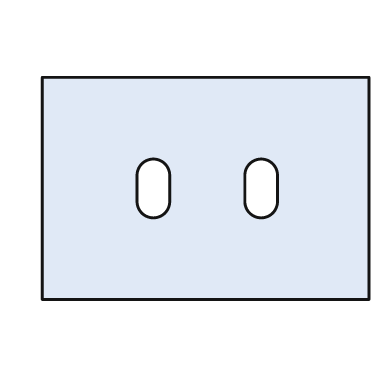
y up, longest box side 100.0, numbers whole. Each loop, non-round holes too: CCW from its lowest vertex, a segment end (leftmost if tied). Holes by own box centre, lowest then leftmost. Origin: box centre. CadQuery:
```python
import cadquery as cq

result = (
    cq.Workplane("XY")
    .moveTo(-50.0, -34.0)
    .lineTo(50.0, -34.0)
    .lineTo(50.0, 34.0)
    .lineTo(-50.0, 34.0)
    .close()
    .moveTo(-21.0, -4.0)
    .threePointArc((-16.0, -9.0), (-11.0, -4.0))
    .lineTo(-11.0, 4.0)
    .threePointArc((-16.0, 9.0), (-21.0, 4.0))
    .close()
    .moveTo(12.0, -4.0)
    .threePointArc((17.0, -9.0), (22.0, -4.0))
    .lineTo(22.0, 4.0)
    .threePointArc((17.0, 9.0), (12.0, 4.0))
    .close()
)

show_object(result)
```